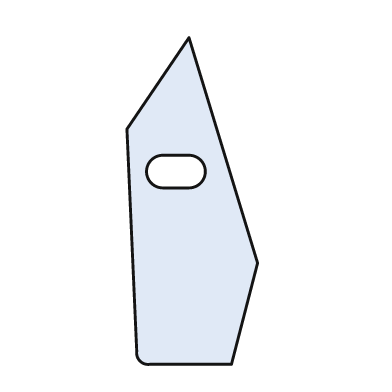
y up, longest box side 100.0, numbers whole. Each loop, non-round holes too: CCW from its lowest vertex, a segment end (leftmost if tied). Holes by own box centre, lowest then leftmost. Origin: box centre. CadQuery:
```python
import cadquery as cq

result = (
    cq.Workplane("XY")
    .moveTo(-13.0, -50.0)
    .lineTo(12.0, -50.0)
    .lineTo(20.0, -19.0)
    .lineTo(-1.0, 50.0)
    .lineTo(-20.0, 22.0)
    .lineTo(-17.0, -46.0)
    .threePointArc((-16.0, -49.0), (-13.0, -50.0))
    .close()
    .moveTo(-9.0, 4.0)
    .lineTo(-1.0, 4.0)
    .threePointArc((4.0, 9.0), (-1.0, 14.0))
    .lineTo(-9.0, 14.0)
    .threePointArc((-14.0, 9.0), (-9.0, 4.0))
    .close()
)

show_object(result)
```